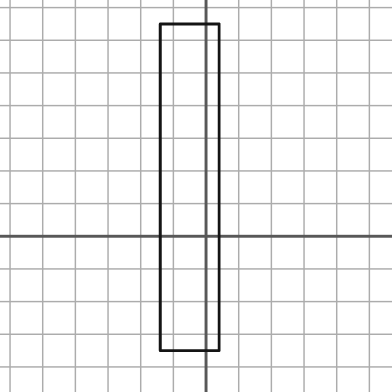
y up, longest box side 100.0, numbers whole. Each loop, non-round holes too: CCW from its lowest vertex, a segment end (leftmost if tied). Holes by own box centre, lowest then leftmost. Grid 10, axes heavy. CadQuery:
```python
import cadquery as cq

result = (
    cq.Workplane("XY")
    .moveTo(-14.0, -35.0)
    .lineTo(4.0, -35.0)
    .lineTo(4.0, 65.0)
    .lineTo(-14.0, 65.0)
    .close()
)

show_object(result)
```